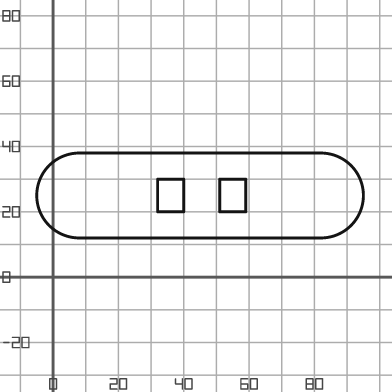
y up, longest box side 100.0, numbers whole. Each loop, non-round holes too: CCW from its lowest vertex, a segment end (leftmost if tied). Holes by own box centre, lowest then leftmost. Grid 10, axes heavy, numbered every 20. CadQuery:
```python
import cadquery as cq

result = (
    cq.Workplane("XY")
    .moveTo(8.0, 12.0)
    .lineTo(82.0, 12.0)
    .threePointArc((95.0, 25.0), (82.0, 38.0))
    .lineTo(8.0, 38.0)
    .threePointArc((-5.0, 25.0), (8.0, 12.0))
    .close()
    .moveTo(32.0, 20.0)
    .lineTo(40.0, 20.0)
    .lineTo(40.0, 30.0)
    .lineTo(32.0, 30.0)
    .close()
    .moveTo(51.0, 20.0)
    .lineTo(59.0, 20.0)
    .lineTo(59.0, 30.0)
    .lineTo(51.0, 30.0)
    .close()
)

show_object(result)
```